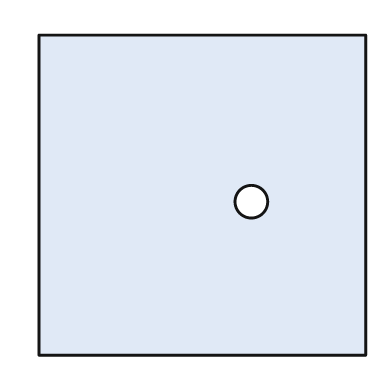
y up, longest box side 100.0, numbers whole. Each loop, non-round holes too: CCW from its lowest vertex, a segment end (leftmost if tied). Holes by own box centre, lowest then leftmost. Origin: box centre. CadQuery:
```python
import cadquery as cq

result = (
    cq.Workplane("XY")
    .moveTo(-50.0, -49.0)
    .lineTo(50.0, -49.0)
    .lineTo(50.0, 49.0)
    .lineTo(-50.0, 49.0)
    .close()
    .moveTo(15.0, -2.0)
    .circle(5.0)
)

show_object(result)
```